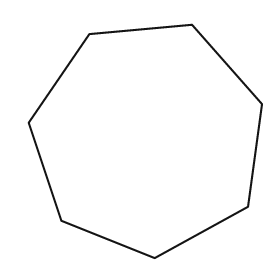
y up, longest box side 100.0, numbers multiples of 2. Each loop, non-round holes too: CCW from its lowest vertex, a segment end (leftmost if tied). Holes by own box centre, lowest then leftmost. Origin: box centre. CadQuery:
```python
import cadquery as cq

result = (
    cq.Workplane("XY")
    .moveTo(4.0, -50.0)
    .lineTo(44.0, -28.0)
    .lineTo(50.0, 16.0)
    .lineTo(20.0, 50.0)
    .lineTo(-24.0, 46.0)
    .lineTo(-50.0, 8.0)
    .lineTo(-36.0, -34.0)
    .close()
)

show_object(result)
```